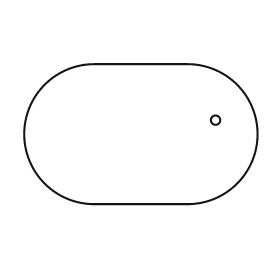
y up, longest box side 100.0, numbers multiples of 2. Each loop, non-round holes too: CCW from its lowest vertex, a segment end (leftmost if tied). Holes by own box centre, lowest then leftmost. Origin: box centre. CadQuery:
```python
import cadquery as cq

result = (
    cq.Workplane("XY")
    .moveTo(-20.0, -30.0)
    .lineTo(20.0, -30.0)
    .threePointArc((50.0, 0.0), (20.0, 30.0))
    .lineTo(-20.0, 30.0)
    .threePointArc((-50.0, 0.0), (-20.0, -30.0))
    .close()
    .moveTo(32.0, 6.0)
    .circle(2.0)
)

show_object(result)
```